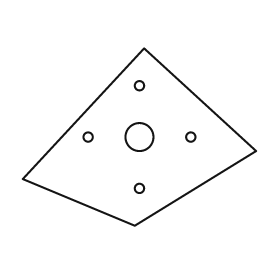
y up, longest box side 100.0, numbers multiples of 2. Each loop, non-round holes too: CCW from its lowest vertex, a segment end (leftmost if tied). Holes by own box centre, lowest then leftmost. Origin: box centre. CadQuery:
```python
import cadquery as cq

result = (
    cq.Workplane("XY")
    .moveTo(-2.0, -38.0)
    .lineTo(50.0, -6.0)
    .lineTo(2.0, 38.0)
    .lineTo(-50.0, -18.0)
    .close()
    .moveTo(0.0, -22.0)
    .circle(2.0)
    .moveTo(-22.0, 0.0)
    .circle(2.0)
    .moveTo(0.0, 0.0)
    .circle(6.0)
    .moveTo(22.0, 0.0)
    .circle(2.0)
    .moveTo(0.0, 22.0)
    .circle(2.0)
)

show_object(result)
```